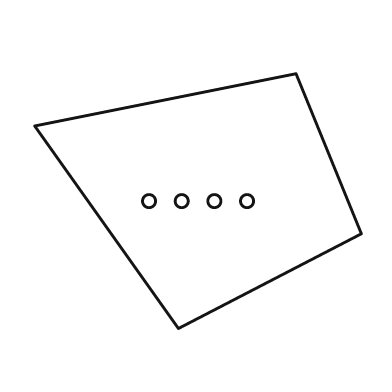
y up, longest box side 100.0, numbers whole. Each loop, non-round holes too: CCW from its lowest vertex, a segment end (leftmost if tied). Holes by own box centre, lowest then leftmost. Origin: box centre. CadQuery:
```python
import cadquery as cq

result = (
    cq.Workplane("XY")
    .moveTo(-6.0, -39.0)
    .lineTo(50.0, -10.0)
    .lineTo(30.0, 39.0)
    .lineTo(-50.0, 23.0)
    .close()
    .moveTo(-15.0, 0.0)
    .circle(2.0)
    .moveTo(-5.0, 0.0)
    .circle(2.0)
    .moveTo(5.0, 0.0)
    .circle(2.0)
    .moveTo(15.0, 0.0)
    .circle(2.0)
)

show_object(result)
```